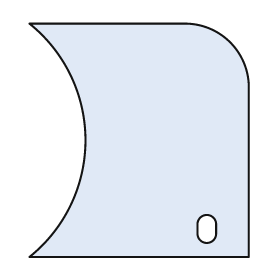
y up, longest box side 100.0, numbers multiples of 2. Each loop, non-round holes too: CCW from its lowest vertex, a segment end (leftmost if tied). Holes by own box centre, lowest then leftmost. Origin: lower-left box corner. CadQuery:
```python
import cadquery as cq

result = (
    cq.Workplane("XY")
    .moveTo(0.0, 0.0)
    .lineTo(94.0, 0.0)
    .lineTo(94.0, 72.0)
    .threePointArc((86.0, 92.0), (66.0, 100.0))
    .lineTo(0.0, 100.0)
    .threePointArc((24.0, 50.0), (0.0, 0.0))
    .close()
    .moveTo(72.0, 10.0)
    .threePointArc((76.0, 6.0), (80.0, 10.0))
    .lineTo(80.0, 14.0)
    .threePointArc((76.0, 18.0), (72.0, 14.0))
    .close()
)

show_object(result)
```